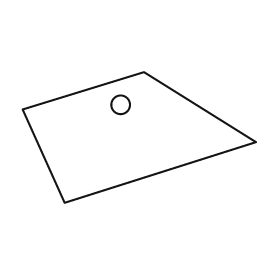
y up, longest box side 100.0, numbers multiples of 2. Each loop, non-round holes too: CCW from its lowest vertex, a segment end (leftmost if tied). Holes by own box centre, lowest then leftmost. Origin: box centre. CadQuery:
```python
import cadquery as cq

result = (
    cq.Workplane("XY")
    .moveTo(-32.0, -28.0)
    .lineTo(50.0, -2.0)
    .lineTo(2.0, 28.0)
    .lineTo(-50.0, 12.0)
    .close()
    .moveTo(-8.0, 14.0)
    .circle(4.0)
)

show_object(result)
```